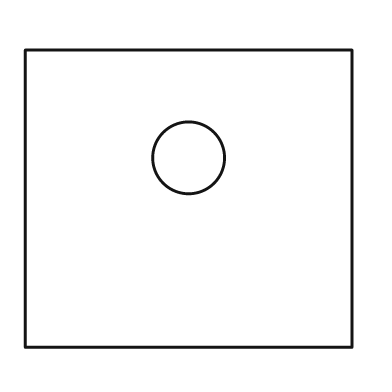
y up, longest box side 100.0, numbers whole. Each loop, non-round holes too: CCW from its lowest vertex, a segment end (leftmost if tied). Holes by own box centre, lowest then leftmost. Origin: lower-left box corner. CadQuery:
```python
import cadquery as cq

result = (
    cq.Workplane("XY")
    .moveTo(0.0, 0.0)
    .lineTo(100.0, 0.0)
    .lineTo(100.0, 91.0)
    .lineTo(0.0, 91.0)
    .close()
    .moveTo(50.0, 58.0)
    .circle(11.0)
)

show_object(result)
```